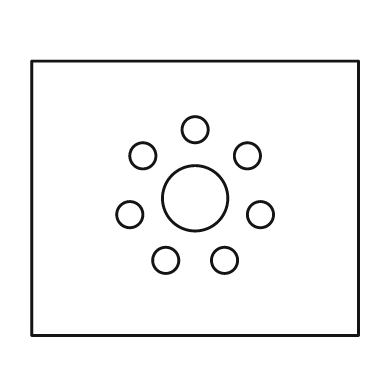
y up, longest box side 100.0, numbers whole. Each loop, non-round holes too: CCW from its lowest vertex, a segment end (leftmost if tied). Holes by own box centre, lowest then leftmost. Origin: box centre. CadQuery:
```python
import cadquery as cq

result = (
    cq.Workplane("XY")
    .moveTo(-50.0, -42.0)
    .lineTo(50.0, -42.0)
    .lineTo(50.0, 42.0)
    .lineTo(-50.0, 42.0)
    .close()
    .moveTo(-9.0, -19.0)
    .circle(4.0)
    .moveTo(9.0, -19.0)
    .circle(4.0)
    .moveTo(-20.0, -5.0)
    .circle(4.0)
    .moveTo(20.0, -5.0)
    .circle(4.0)
    .moveTo(0.0, 0.0)
    .circle(10.0)
    .moveTo(-16.0, 13.0)
    .circle(4.0)
    .moveTo(16.0, 13.0)
    .circle(4.0)
    .moveTo(0.0, 21.0)
    .circle(4.0)
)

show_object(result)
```